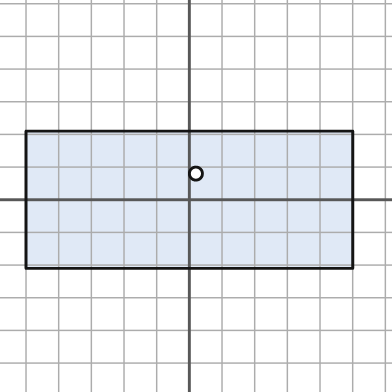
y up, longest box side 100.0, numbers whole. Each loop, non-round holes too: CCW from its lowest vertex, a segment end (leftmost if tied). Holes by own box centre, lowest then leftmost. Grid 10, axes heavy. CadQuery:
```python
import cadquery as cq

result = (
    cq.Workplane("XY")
    .moveTo(-50.0, -21.0)
    .lineTo(50.0, -21.0)
    .lineTo(50.0, 21.0)
    .lineTo(-50.0, 21.0)
    .close()
    .moveTo(2.0, 8.0)
    .circle(2.0)
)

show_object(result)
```